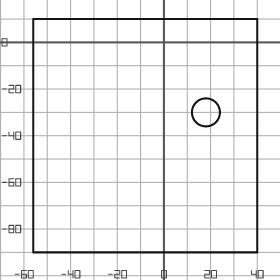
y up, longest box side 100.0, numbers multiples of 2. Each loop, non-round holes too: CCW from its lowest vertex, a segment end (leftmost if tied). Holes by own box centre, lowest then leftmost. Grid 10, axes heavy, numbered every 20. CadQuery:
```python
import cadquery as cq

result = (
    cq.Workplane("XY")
    .moveTo(-56.0, -90.0)
    .lineTo(40.0, -90.0)
    .lineTo(40.0, 10.0)
    .lineTo(-56.0, 10.0)
    .close()
    .moveTo(18.0, -30.0)
    .circle(6.0)
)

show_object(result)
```